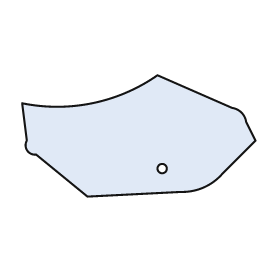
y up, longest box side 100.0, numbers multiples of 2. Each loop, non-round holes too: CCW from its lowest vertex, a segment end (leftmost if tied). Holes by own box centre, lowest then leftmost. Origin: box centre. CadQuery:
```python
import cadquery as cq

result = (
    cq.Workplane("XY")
    .moveTo(-22.0, -26.0)
    .lineTo(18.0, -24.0)
    .threePointArc((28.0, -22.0), (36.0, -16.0))
    .lineTo(50.0, -2.0)
    .lineTo(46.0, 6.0)
    .threePointArc((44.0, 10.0), (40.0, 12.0))
    .lineTo(8.0, 26.0)
    .threePointArc((-20.0, 14.0), (-50.0, 14.0))
    .lineTo(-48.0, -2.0)
    .threePointArc((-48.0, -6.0), (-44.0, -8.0))
    .close()
    .moveTo(10.0, -14.0)
    .circle(2.0)
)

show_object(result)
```